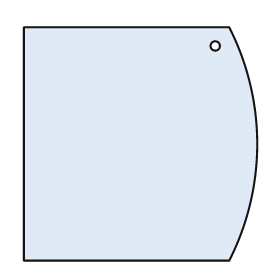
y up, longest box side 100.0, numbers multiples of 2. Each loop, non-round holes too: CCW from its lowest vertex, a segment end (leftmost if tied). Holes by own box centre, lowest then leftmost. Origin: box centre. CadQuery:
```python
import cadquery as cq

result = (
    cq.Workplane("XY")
    .moveTo(-50.0, -50.0)
    .lineTo(38.0, -50.0)
    .threePointArc((50.0, 0.0), (38.0, 50.0))
    .lineTo(-50.0, 50.0)
    .close()
    .moveTo(32.0, 42.0)
    .circle(2.0)
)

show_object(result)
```